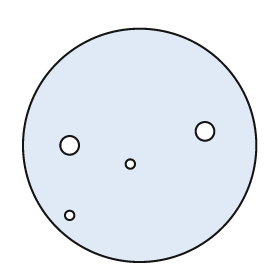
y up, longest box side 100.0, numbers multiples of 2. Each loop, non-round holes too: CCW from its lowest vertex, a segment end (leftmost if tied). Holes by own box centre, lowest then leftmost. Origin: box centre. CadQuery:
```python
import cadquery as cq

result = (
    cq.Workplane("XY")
    .moveTo(0.0, 0.0)
    .circle(50.0)
    .moveTo(-30.0, -30.0)
    .circle(2.0)
    .moveTo(-4.0, -8.0)
    .circle(2.0)
    .moveTo(-30.0, 0.0)
    .circle(4.0)
    .moveTo(28.0, 6.0)
    .circle(4.0)
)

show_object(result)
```